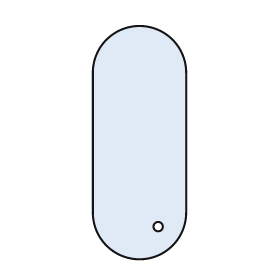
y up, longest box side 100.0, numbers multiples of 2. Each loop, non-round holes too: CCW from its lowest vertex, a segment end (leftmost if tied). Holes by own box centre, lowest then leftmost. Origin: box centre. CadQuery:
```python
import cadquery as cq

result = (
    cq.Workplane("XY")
    .moveTo(-20.0, -30.0)
    .threePointArc((0.0, -50.0), (20.0, -30.0))
    .lineTo(20.0, 30.0)
    .threePointArc((0.0, 50.0), (-20.0, 30.0))
    .close()
    .moveTo(8.0, -36.0)
    .circle(2.0)
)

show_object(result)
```